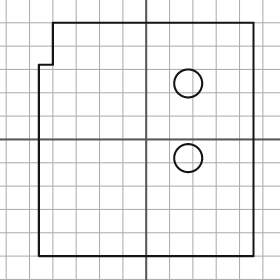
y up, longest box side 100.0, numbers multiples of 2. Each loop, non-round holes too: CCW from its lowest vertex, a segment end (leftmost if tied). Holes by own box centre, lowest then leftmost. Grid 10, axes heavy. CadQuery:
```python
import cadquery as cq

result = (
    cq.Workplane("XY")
    .moveTo(-46.0, -50.0)
    .lineTo(46.0, -50.0)
    .lineTo(46.0, 50.0)
    .lineTo(-40.0, 50.0)
    .lineTo(-40.0, 32.0)
    .lineTo(-46.0, 32.0)
    .close()
    .moveTo(18.0, -8.0)
    .circle(6.0)
    .moveTo(18.0, 24.0)
    .circle(6.0)
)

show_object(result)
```